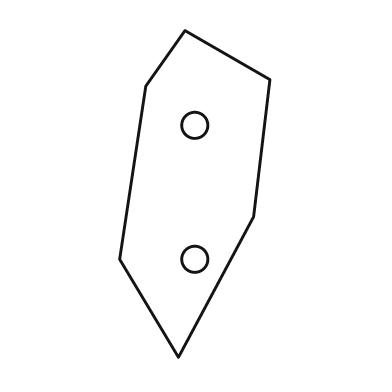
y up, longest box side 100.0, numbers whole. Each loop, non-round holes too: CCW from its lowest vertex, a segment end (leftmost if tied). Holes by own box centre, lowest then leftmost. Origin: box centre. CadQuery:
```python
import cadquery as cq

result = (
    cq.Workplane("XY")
    .moveTo(-5.0, -50.0)
    .lineTo(18.0, -7.0)
    .lineTo(23.0, 35.0)
    .lineTo(-3.0, 50.0)
    .lineTo(-15.0, 33.0)
    .lineTo(-23.0, -20.0)
    .close()
    .moveTo(0.0, -20.0)
    .circle(4.0)
    .moveTo(0.0, 21.0)
    .circle(4.0)
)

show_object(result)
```